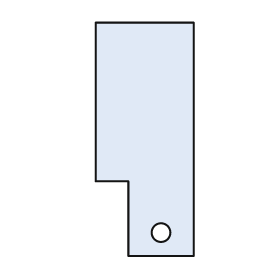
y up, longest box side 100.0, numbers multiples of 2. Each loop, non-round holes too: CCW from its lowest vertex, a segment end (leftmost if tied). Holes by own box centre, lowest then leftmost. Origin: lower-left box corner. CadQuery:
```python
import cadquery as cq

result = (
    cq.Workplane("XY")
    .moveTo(14.0, 0.0)
    .lineTo(42.0, 0.0)
    .lineTo(42.0, 100.0)
    .lineTo(0.0, 100.0)
    .lineTo(0.0, 32.0)
    .lineTo(14.0, 32.0)
    .close()
    .moveTo(28.0, 10.0)
    .circle(4.0)
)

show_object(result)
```